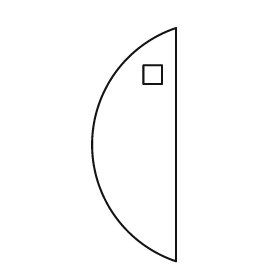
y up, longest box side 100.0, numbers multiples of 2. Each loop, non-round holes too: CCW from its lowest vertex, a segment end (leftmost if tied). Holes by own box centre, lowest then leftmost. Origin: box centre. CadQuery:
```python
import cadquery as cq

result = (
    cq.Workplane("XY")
    .moveTo(18.0, -50.0)
    .lineTo(18.0, 50.0)
    .threePointArc((-18.0, 0.0), (18.0, -50.0))
    .close()
    .moveTo(4.0, 26.0)
    .lineTo(12.0, 26.0)
    .lineTo(12.0, 34.0)
    .lineTo(4.0, 34.0)
    .close()
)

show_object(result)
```